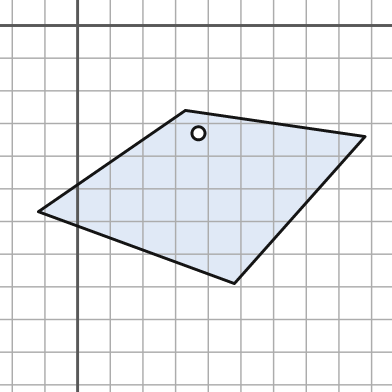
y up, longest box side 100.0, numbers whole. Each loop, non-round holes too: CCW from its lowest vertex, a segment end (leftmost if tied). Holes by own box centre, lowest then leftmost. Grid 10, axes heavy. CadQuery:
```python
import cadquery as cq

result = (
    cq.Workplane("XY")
    .moveTo(48.0, -79.0)
    .lineTo(88.0, -34.0)
    .lineTo(33.0, -26.0)
    .lineTo(-12.0, -57.0)
    .close()
    .moveTo(37.0, -33.0)
    .circle(2.0)
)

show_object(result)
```